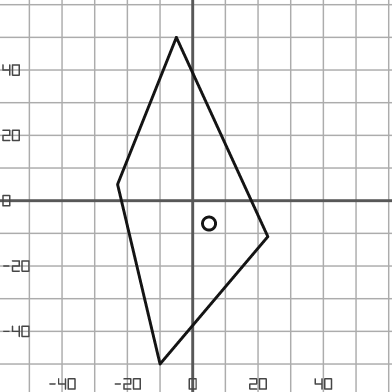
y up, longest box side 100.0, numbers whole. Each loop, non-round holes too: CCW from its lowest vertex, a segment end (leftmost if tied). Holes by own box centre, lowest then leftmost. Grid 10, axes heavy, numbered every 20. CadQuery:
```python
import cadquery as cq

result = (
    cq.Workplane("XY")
    .moveTo(-10.0, -50.0)
    .lineTo(23.0, -11.0)
    .lineTo(-5.0, 50.0)
    .lineTo(-23.0, 5.0)
    .close()
    .moveTo(5.0, -7.0)
    .circle(2.0)
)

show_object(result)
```